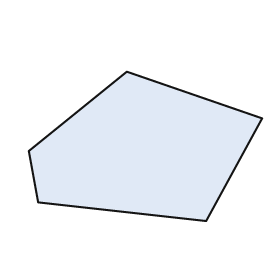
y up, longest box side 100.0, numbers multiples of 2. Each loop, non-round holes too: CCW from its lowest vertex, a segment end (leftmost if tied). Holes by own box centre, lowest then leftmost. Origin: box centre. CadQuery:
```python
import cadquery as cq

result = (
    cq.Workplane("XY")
    .moveTo(26.0, -32.0)
    .lineTo(50.0, 12.0)
    .lineTo(-8.0, 32.0)
    .lineTo(-50.0, -2.0)
    .lineTo(-46.0, -24.0)
    .close()
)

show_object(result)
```